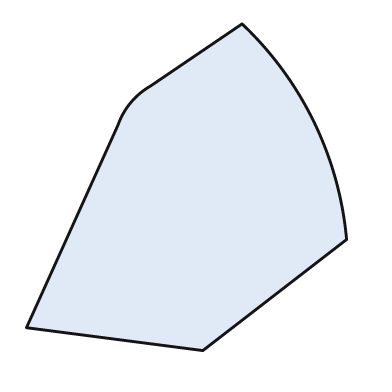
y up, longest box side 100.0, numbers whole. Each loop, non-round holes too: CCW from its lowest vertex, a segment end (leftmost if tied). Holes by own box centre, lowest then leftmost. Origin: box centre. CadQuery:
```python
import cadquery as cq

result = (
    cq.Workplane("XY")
    .moveTo(5.0, -50.0)
    .lineTo(49.0, -16.0)
    .threePointArc((39.0, 20.0), (17.0, 50.0))
    .lineTo(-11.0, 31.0)
    .threePointArc((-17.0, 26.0), (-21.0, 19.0))
    .lineTo(-49.0, -43.0)
    .close()
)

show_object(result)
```